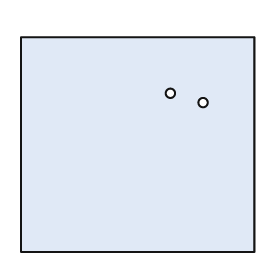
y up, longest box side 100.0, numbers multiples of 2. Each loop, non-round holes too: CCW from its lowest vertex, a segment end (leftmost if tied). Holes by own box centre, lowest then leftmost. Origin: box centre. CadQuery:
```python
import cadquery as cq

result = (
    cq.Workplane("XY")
    .moveTo(-50.0, -46.0)
    .lineTo(50.0, -46.0)
    .lineTo(50.0, 46.0)
    .lineTo(-50.0, 46.0)
    .close()
    .moveTo(28.0, 18.0)
    .circle(2.0)
    .moveTo(14.0, 22.0)
    .circle(2.0)
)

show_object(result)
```